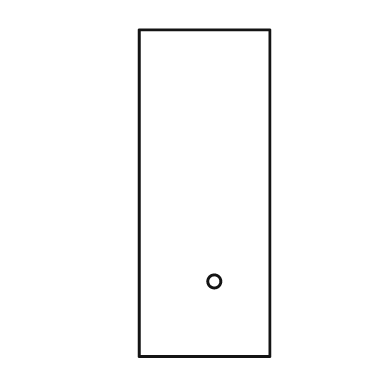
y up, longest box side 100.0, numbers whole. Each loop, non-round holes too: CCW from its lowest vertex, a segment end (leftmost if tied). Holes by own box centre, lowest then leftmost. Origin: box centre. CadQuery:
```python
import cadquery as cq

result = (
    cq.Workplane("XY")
    .moveTo(-20.0, -50.0)
    .lineTo(20.0, -50.0)
    .lineTo(20.0, 50.0)
    .lineTo(-20.0, 50.0)
    .close()
    .moveTo(3.0, -27.0)
    .circle(2.0)
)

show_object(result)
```